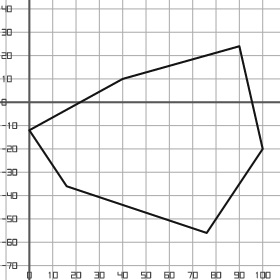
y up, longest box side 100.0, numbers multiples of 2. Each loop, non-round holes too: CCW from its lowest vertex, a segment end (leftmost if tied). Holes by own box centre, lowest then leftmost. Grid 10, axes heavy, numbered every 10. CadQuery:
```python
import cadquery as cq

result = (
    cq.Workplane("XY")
    .moveTo(76.0, -56.0)
    .lineTo(100.0, -20.0)
    .lineTo(90.0, 24.0)
    .lineTo(40.0, 10.0)
    .lineTo(0.0, -12.0)
    .lineTo(16.0, -36.0)
    .close()
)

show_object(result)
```